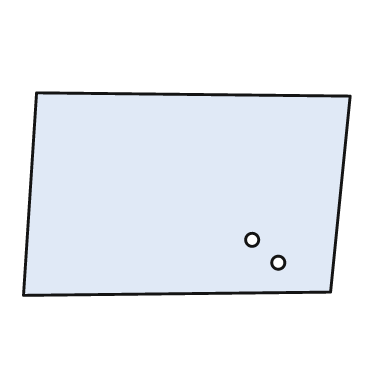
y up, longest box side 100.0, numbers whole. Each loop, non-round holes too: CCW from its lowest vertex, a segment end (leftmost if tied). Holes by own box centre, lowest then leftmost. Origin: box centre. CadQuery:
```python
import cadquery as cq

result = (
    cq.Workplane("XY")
    .moveTo(-50.0, -31.0)
    .lineTo(44.0, -30.0)
    .lineTo(50.0, 30.0)
    .lineTo(-46.0, 31.0)
    .close()
    .moveTo(28.0, -21.0)
    .circle(2.0)
    .moveTo(20.0, -14.0)
    .circle(2.0)
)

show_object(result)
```